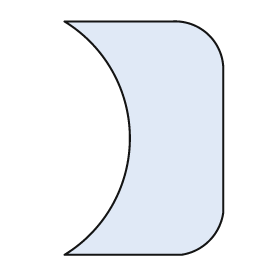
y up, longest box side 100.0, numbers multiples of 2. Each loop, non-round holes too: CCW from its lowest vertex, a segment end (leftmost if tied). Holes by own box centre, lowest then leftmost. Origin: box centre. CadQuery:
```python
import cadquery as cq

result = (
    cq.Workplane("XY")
    .moveTo(-34.0, -50.0)
    .lineTo(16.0, -50.0)
    .threePointArc((28.0, -44.0), (34.0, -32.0))
    .lineTo(34.0, 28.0)
    .threePointArc((28.0, 44.0), (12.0, 50.0))
    .lineTo(-34.0, 50.0)
    .threePointArc((-6.0, 0.0), (-34.0, -50.0))
    .close()
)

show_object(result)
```